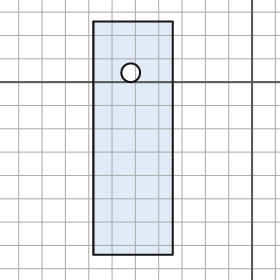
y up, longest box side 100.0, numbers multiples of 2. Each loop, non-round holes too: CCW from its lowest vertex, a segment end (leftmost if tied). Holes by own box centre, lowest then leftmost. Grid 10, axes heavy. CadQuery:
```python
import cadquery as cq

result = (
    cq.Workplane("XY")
    .moveTo(-68.0, -74.0)
    .lineTo(-34.0, -74.0)
    .lineTo(-34.0, 26.0)
    .lineTo(-68.0, 26.0)
    .close()
    .moveTo(-52.0, 4.0)
    .circle(4.0)
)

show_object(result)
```